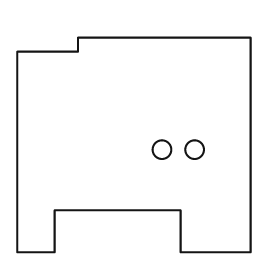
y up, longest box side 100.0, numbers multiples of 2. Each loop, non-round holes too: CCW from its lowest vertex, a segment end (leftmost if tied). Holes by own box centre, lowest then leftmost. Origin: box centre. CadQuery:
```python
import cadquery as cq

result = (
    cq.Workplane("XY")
    .moveTo(-50.0, -46.0)
    .lineTo(-34.0, -46.0)
    .lineTo(-34.0, -28.0)
    .lineTo(20.0, -28.0)
    .lineTo(20.0, -46.0)
    .lineTo(50.0, -46.0)
    .lineTo(50.0, 46.0)
    .lineTo(-24.0, 46.0)
    .lineTo(-24.0, 40.0)
    .lineTo(-50.0, 40.0)
    .close()
    .moveTo(12.0, -2.0)
    .circle(4.0)
    .moveTo(26.0, -2.0)
    .circle(4.0)
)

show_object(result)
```